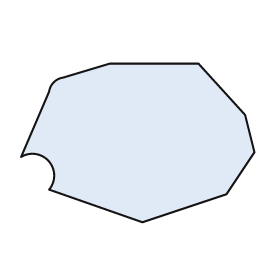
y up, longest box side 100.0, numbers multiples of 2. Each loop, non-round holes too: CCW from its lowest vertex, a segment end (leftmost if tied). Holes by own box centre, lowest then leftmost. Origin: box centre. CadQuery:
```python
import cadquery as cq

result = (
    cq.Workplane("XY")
    .moveTo(2.0, -34.0)
    .lineTo(38.0, -22.0)
    .lineTo(50.0, -4.0)
    .lineTo(46.0, 12.0)
    .lineTo(26.0, 34.0)
    .lineTo(-12.0, 34.0)
    .lineTo(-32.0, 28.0)
    .threePointArc((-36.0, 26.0), (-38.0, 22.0))
    .lineTo(-50.0, -6.0)
    .threePointArc((-38.0, -8.0), (-38.0, -20.0))
    .close()
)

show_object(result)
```